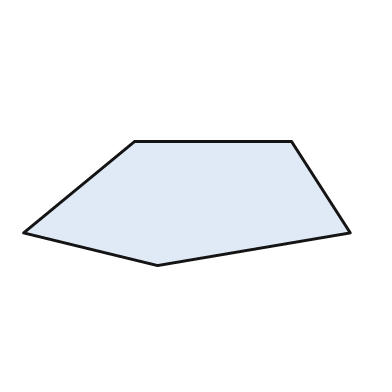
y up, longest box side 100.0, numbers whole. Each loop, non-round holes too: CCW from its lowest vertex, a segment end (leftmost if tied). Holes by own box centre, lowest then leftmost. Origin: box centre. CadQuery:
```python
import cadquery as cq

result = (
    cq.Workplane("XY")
    .moveTo(-9.0, -19.0)
    .lineTo(50.0, -9.0)
    .lineTo(32.0, 19.0)
    .lineTo(-16.0, 19.0)
    .lineTo(-50.0, -9.0)
    .close()
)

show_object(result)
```